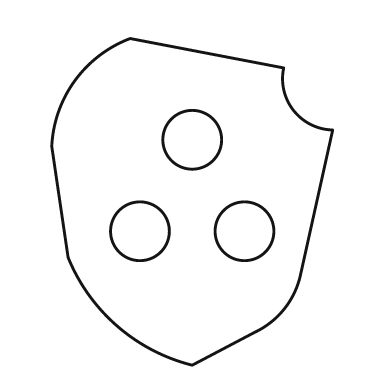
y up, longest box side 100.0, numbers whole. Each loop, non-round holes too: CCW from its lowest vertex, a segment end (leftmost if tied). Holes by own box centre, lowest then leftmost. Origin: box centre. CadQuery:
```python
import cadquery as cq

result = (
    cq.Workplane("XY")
    .moveTo(0.0, -50.0)
    .lineTo(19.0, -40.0)
    .threePointArc((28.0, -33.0), (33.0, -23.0))
    .lineTo(43.0, 22.0)
    .threePointArc((31.0, 28.0), (28.0, 41.0))
    .lineTo(-19.0, 50.0)
    .threePointArc((-36.0, 37.0), (-43.0, 17.0))
    .lineTo(-38.0, -17.0)
    .threePointArc((-23.0, -38.0), (0.0, -50.0))
    .close()
    .moveTo(-16.0, -9.0)
    .circle(9.0)
    .moveTo(16.0, -9.0)
    .circle(9.0)
    .moveTo(0.0, 19.0)
    .circle(9.0)
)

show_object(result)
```